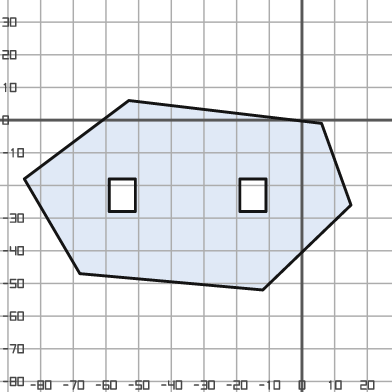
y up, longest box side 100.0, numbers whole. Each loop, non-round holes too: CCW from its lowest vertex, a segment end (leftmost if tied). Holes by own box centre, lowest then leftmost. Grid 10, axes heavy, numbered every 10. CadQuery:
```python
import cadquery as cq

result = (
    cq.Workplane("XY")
    .moveTo(-12.0, -52.0)
    .lineTo(15.0, -26.0)
    .lineTo(6.0, -1.0)
    .lineTo(-53.0, 6.0)
    .lineTo(-85.0, -18.0)
    .lineTo(-68.0, -47.0)
    .close()
    .moveTo(-59.0, -28.0)
    .lineTo(-51.0, -28.0)
    .lineTo(-51.0, -18.0)
    .lineTo(-59.0, -18.0)
    .close()
    .moveTo(-19.0, -28.0)
    .lineTo(-11.0, -28.0)
    .lineTo(-11.0, -18.0)
    .lineTo(-19.0, -18.0)
    .close()
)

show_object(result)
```